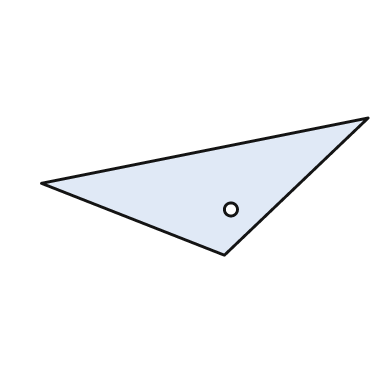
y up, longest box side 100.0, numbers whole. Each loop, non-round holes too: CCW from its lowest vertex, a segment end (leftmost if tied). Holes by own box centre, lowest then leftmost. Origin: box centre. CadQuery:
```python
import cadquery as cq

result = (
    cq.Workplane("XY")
    .moveTo(6.0, -21.0)
    .lineTo(50.0, 21.0)
    .lineTo(-50.0, 1.0)
    .close()
    .moveTo(8.0, -7.0)
    .circle(2.0)
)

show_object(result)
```